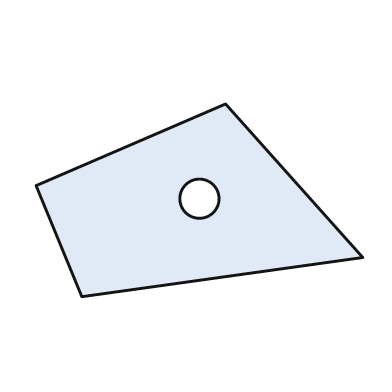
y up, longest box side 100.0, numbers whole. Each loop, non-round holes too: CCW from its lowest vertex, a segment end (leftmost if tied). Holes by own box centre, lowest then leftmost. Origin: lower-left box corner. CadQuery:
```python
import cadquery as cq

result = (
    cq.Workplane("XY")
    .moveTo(14.0, 0.0)
    .lineTo(100.0, 12.0)
    .lineTo(58.0, 59.0)
    .lineTo(0.0, 34.0)
    .close()
    .moveTo(50.0, 30.0)
    .circle(6.0)
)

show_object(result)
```